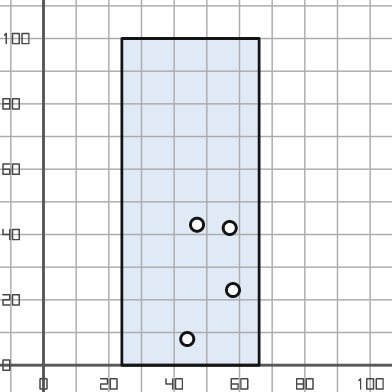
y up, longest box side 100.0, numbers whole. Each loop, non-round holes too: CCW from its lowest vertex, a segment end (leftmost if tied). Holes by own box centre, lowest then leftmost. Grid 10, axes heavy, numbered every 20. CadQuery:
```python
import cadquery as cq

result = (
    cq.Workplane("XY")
    .moveTo(24.0, 0.0)
    .lineTo(66.0, 0.0)
    .lineTo(66.0, 100.0)
    .lineTo(24.0, 100.0)
    .close()
    .moveTo(44.0, 8.0)
    .circle(2.0)
    .moveTo(58.0, 23.0)
    .circle(2.0)
    .moveTo(57.0, 42.0)
    .circle(2.0)
    .moveTo(47.0, 43.0)
    .circle(2.0)
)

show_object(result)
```